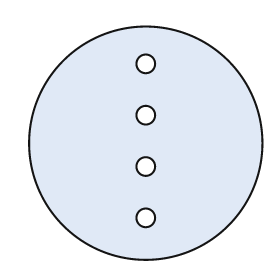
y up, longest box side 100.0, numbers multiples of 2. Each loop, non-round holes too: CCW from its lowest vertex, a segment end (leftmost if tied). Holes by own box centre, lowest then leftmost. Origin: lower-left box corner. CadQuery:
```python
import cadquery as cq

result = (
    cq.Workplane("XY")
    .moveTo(50.0, 50.0)
    .circle(50.0)
    .moveTo(50.0, 18.0)
    .circle(4.0)
    .moveTo(50.0, 40.0)
    .circle(4.0)
    .moveTo(50.0, 62.0)
    .circle(4.0)
    .moveTo(50.0, 84.0)
    .circle(4.0)
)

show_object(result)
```